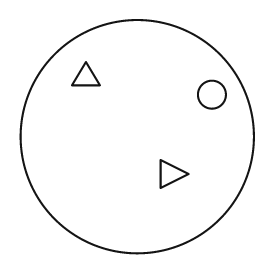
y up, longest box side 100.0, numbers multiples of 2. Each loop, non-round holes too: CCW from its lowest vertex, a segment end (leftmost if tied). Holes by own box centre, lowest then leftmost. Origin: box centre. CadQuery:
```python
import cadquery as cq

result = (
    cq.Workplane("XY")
    .moveTo(0.0, 0.0)
    .circle(50.0)
    .moveTo(10.0, -22.0)
    .lineTo(22.0, -16.0)
    .lineTo(10.0, -10.0)
    .close()
    .moveTo(32.0, 18.0)
    .circle(6.0)
    .moveTo(-28.0, 22.0)
    .lineTo(-16.0, 22.0)
    .lineTo(-22.0, 32.0)
    .close()
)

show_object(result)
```